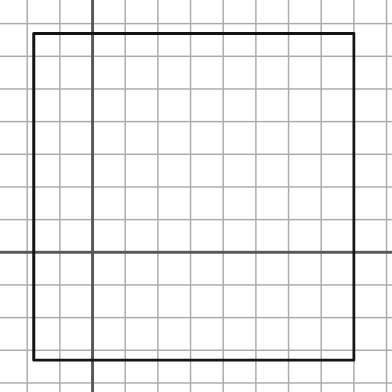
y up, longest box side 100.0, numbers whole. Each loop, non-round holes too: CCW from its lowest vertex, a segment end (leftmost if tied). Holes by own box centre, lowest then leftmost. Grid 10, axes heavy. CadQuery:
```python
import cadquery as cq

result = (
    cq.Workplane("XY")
    .moveTo(-18.0, -33.0)
    .lineTo(80.0, -33.0)
    .lineTo(80.0, 67.0)
    .lineTo(-18.0, 67.0)
    .close()
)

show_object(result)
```